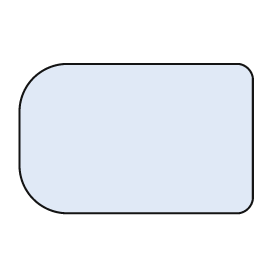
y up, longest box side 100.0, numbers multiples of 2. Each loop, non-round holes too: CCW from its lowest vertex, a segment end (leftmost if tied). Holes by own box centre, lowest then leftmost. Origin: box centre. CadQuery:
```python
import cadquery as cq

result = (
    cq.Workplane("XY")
    .moveTo(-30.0, -32.0)
    .lineTo(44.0, -32.0)
    .threePointArc((48.0, -30.0), (50.0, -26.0))
    .lineTo(50.0, 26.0)
    .threePointArc((48.0, 30.0), (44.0, 32.0))
    .lineTo(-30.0, 32.0)
    .threePointArc((-44.0, 26.0), (-50.0, 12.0))
    .lineTo(-50.0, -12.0)
    .threePointArc((-44.0, -26.0), (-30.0, -32.0))
    .close()
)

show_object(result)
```